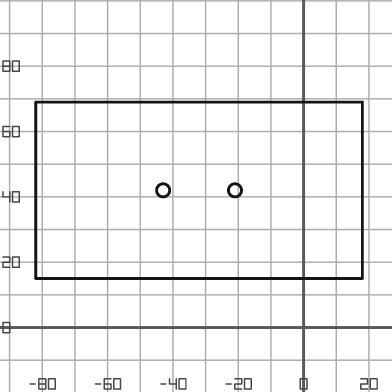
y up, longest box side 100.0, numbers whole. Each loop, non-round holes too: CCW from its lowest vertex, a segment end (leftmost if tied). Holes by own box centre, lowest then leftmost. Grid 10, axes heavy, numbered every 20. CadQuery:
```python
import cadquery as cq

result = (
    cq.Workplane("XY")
    .moveTo(-82.0, 15.0)
    .lineTo(18.0, 15.0)
    .lineTo(18.0, 69.0)
    .lineTo(-82.0, 69.0)
    .close()
    .moveTo(-43.0, 42.0)
    .circle(2.0)
    .moveTo(-21.0, 42.0)
    .circle(2.0)
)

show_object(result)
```